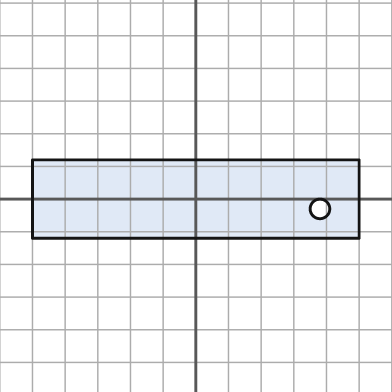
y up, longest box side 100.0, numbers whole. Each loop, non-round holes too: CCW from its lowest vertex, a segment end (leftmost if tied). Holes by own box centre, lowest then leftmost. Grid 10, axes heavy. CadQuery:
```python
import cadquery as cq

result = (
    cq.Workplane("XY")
    .moveTo(-50.0, -12.0)
    .lineTo(50.0, -12.0)
    .lineTo(50.0, 12.0)
    .lineTo(-50.0, 12.0)
    .close()
    .moveTo(38.0, -3.0)
    .circle(3.0)
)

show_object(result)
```